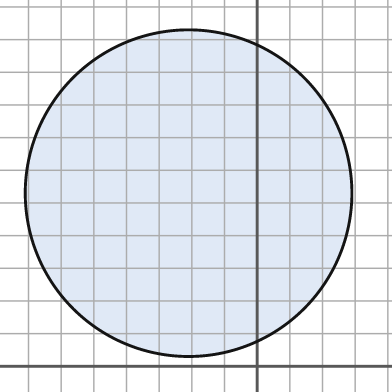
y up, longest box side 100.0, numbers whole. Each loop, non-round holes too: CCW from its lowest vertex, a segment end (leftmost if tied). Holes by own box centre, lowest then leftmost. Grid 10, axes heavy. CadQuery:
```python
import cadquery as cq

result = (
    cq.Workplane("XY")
    .moveTo(-21.0, 53.0)
    .circle(50.0)
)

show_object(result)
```